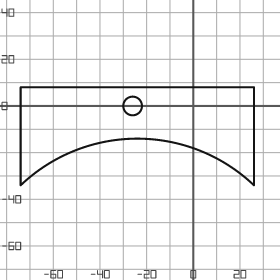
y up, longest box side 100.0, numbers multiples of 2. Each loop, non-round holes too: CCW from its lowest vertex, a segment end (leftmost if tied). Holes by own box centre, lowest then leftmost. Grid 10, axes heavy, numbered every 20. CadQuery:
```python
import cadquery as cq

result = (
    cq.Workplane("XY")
    .moveTo(-74.0, -34.0)
    .threePointArc((-24.0, -14.0), (26.0, -34.0))
    .lineTo(26.0, 8.0)
    .lineTo(-74.0, 8.0)
    .close()
    .moveTo(-26.0, 0.0)
    .circle(4.0)
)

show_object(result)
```